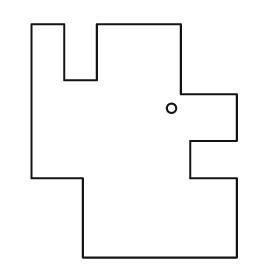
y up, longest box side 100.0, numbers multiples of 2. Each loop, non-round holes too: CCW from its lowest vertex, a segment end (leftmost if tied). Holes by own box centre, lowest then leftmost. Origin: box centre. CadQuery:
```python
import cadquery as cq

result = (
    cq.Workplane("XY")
    .moveTo(-22.0, -50.0)
    .lineTo(44.0, -50.0)
    .lineTo(44.0, -16.0)
    .lineTo(24.0, -16.0)
    .lineTo(24.0, 0.0)
    .lineTo(44.0, 0.0)
    .lineTo(44.0, 20.0)
    .lineTo(20.0, 20.0)
    .lineTo(20.0, 50.0)
    .lineTo(-16.0, 50.0)
    .lineTo(-16.0, 26.0)
    .lineTo(-30.0, 26.0)
    .lineTo(-30.0, 50.0)
    .lineTo(-44.0, 50.0)
    .lineTo(-44.0, -16.0)
    .lineTo(-22.0, -16.0)
    .close()
    .moveTo(16.0, 14.0)
    .circle(2.0)
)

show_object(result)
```